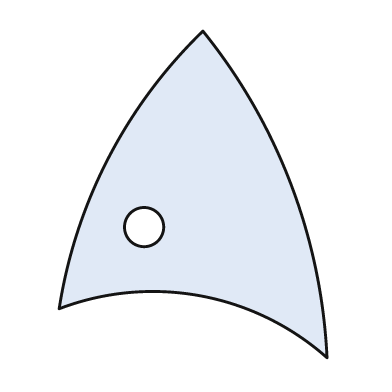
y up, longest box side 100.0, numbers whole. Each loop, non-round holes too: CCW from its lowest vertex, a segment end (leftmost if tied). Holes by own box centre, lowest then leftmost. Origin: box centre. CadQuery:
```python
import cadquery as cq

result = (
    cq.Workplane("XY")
    .moveTo(41.0, -50.0)
    .threePointArc((30.0, 3.0), (3.0, 50.0))
    .threePointArc((-26.0, 11.0), (-41.0, -35.0))
    .threePointArc((2.0, -31.0), (41.0, -50.0))
    .close()
    .moveTo(-15.0, -10.0)
    .circle(6.0)
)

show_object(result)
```